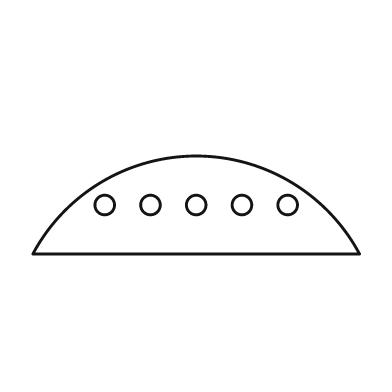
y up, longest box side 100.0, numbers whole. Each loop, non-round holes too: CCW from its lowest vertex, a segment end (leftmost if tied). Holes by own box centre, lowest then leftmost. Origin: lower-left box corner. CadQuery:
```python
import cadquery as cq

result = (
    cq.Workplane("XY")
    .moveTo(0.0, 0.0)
    .lineTo(100.0, 0.0)
    .threePointArc((50.0, 30.0), (0.0, 0.0))
    .close()
    .moveTo(22.0, 15.0)
    .circle(3.0)
    .moveTo(36.0, 15.0)
    .circle(3.0)
    .moveTo(50.0, 15.0)
    .circle(3.0)
    .moveTo(64.0, 15.0)
    .circle(3.0)
    .moveTo(78.0, 15.0)
    .circle(3.0)
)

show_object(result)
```